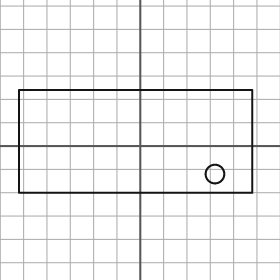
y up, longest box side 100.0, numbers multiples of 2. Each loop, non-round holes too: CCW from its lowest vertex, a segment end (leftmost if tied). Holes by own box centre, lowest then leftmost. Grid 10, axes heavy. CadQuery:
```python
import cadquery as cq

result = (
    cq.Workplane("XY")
    .moveTo(-52.0, -20.0)
    .lineTo(48.0, -20.0)
    .lineTo(48.0, 24.0)
    .lineTo(-52.0, 24.0)
    .close()
    .moveTo(32.0, -12.0)
    .circle(4.0)
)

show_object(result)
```